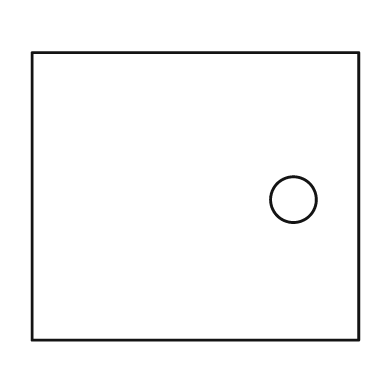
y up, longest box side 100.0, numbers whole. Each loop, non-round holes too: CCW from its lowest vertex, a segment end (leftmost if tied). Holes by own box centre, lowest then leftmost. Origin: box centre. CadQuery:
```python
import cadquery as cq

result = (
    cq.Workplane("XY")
    .moveTo(-50.0, -44.0)
    .lineTo(50.0, -44.0)
    .lineTo(50.0, 44.0)
    .lineTo(-50.0, 44.0)
    .close()
    .moveTo(30.0, -1.0)
    .circle(7.0)
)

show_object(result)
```